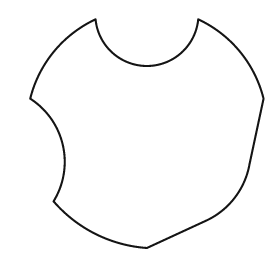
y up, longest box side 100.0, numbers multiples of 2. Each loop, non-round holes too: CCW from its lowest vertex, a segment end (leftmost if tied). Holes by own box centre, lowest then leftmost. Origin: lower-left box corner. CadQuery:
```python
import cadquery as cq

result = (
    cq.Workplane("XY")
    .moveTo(50.0, 0.0)
    .lineTo(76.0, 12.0)
    .threePointArc((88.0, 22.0), (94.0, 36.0))
    .lineTo(100.0, 64.0)
    .threePointArc((90.0, 84.0), (72.0, 98.0))
    .threePointArc((50.0, 78.0), (28.0, 98.0))
    .threePointArc((10.0, 84.0), (0.0, 64.0))
    .threePointArc((14.0, 44.0), (10.0, 20.0))
    .threePointArc((28.0, 6.0), (50.0, 0.0))
    .close()
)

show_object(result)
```